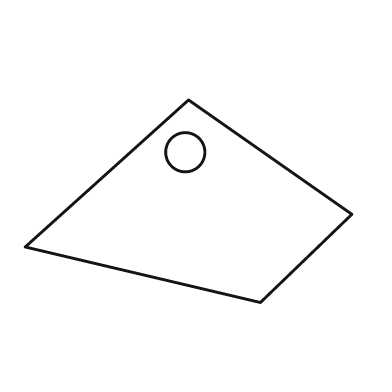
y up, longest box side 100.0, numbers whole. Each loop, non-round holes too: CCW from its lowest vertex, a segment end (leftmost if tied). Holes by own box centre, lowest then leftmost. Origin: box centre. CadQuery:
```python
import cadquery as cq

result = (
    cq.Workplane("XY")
    .moveTo(22.0, -31.0)
    .lineTo(50.0, -4.0)
    .lineTo(0.0, 31.0)
    .lineTo(-50.0, -14.0)
    .close()
    .moveTo(-1.0, 15.0)
    .circle(6.0)
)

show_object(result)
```